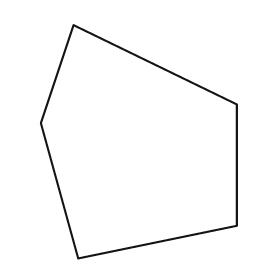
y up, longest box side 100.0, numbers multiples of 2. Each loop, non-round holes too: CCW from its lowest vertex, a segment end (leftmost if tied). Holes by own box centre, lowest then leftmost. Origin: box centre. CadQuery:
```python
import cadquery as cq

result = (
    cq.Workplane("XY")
    .moveTo(-26.0, -50.0)
    .lineTo(42.0, -36.0)
    .lineTo(42.0, 16.0)
    .lineTo(-28.0, 50.0)
    .lineTo(-42.0, 8.0)
    .close()
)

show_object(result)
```